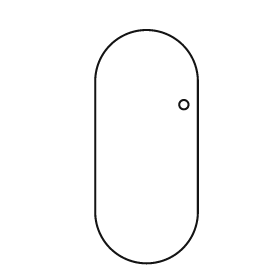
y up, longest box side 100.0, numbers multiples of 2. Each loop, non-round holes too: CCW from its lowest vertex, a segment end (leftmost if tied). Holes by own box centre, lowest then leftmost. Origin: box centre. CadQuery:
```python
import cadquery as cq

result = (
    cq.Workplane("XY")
    .moveTo(-22.0, -28.0)
    .threePointArc((0.0, -50.0), (22.0, -28.0))
    .lineTo(22.0, 28.0)
    .threePointArc((0.0, 50.0), (-22.0, 28.0))
    .close()
    .moveTo(16.0, 18.0)
    .circle(2.0)
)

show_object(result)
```